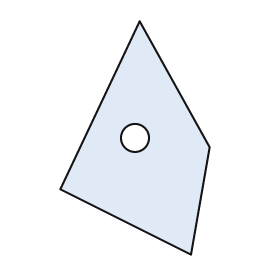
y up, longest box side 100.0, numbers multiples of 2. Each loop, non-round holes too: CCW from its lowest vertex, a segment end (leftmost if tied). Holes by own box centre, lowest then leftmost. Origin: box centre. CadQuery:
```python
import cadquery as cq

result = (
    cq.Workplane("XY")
    .moveTo(24.0, -50.0)
    .lineTo(32.0, -4.0)
    .lineTo(2.0, 50.0)
    .lineTo(-32.0, -22.0)
    .close()
    .moveTo(0.0, 0.0)
    .circle(6.0)
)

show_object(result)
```